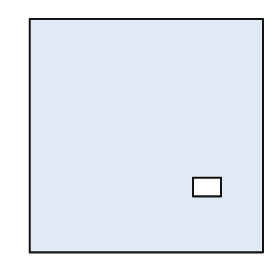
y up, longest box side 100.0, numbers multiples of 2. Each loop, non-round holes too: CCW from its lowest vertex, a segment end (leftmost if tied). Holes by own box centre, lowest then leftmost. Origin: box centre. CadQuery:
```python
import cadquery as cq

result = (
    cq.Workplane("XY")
    .moveTo(-50.0, -50.0)
    .lineTo(50.0, -50.0)
    .lineTo(50.0, 50.0)
    .lineTo(-50.0, 50.0)
    .close()
    .moveTo(20.0, -26.0)
    .lineTo(32.0, -26.0)
    .lineTo(32.0, -18.0)
    .lineTo(20.0, -18.0)
    .close()
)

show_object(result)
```